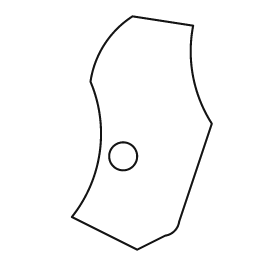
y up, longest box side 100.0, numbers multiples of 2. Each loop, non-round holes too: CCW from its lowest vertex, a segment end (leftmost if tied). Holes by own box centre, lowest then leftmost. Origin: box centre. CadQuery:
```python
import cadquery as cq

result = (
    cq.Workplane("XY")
    .moveTo(-2.0, -50.0)
    .lineTo(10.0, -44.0)
    .threePointArc((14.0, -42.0), (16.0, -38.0))
    .lineTo(30.0, 4.0)
    .threePointArc((22.0, 24.0), (22.0, 46.0))
    .lineTo(-4.0, 50.0)
    .threePointArc((-16.0, 38.0), (-22.0, 22.0))
    .threePointArc((-18.0, -8.0), (-30.0, -36.0))
    .close()
    .moveTo(-8.0, -10.0)
    .circle(6.0)
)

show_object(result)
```